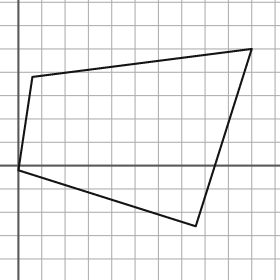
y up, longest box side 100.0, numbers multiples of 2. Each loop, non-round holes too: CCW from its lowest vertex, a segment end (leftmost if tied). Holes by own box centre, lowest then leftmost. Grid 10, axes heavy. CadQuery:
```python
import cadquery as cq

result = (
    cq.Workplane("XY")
    .moveTo(76.0, -26.0)
    .lineTo(100.0, 50.0)
    .lineTo(6.0, 38.0)
    .lineTo(0.0, -2.0)
    .close()
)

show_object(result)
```